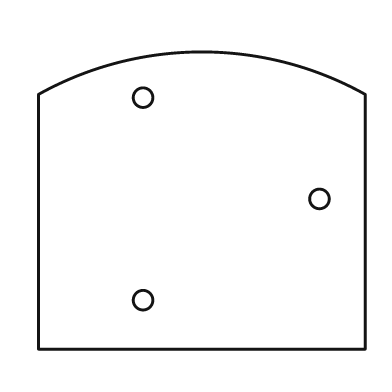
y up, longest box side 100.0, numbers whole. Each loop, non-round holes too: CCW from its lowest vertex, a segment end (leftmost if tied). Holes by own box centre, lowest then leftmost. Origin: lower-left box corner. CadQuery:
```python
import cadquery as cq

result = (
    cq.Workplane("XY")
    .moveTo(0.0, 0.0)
    .lineTo(100.0, 0.0)
    .lineTo(100.0, 78.0)
    .threePointArc((50.0, 91.0), (0.0, 78.0))
    .close()
    .moveTo(32.0, 15.0)
    .circle(3.0)
    .moveTo(86.0, 46.0)
    .circle(3.0)
    .moveTo(32.0, 77.0)
    .circle(3.0)
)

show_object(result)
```